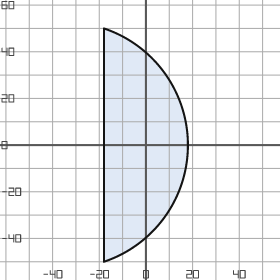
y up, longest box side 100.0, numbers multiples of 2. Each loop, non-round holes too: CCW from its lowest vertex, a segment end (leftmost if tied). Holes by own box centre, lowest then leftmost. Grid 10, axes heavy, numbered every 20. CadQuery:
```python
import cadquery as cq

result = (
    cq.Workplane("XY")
    .moveTo(-18.0, -50.0)
    .threePointArc((18.0, 0.0), (-18.0, 50.0))
    .close()
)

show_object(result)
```